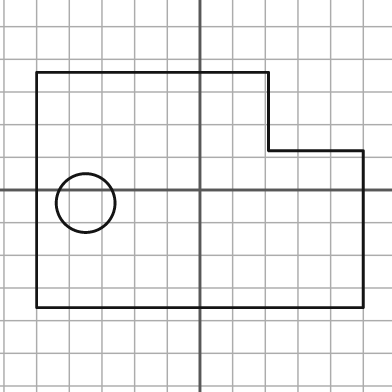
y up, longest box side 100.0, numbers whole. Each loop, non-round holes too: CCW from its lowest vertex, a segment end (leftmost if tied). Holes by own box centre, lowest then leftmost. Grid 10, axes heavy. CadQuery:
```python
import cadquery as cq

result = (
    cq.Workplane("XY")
    .moveTo(-50.0, -36.0)
    .lineTo(50.0, -36.0)
    .lineTo(50.0, 12.0)
    .lineTo(21.0, 12.0)
    .lineTo(21.0, 36.0)
    .lineTo(-50.0, 36.0)
    .close()
    .moveTo(-35.0, -4.0)
    .circle(9.0)
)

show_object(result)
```